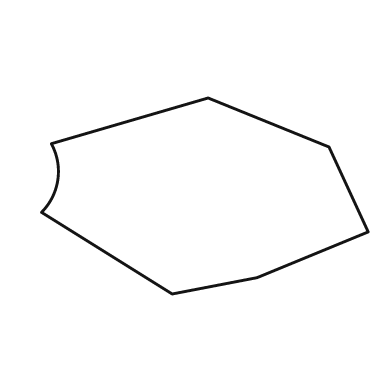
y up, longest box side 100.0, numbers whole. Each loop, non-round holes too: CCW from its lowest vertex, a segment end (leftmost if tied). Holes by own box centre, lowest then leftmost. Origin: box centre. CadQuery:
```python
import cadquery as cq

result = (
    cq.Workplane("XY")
    .moveTo(-10.0, -30.0)
    .lineTo(16.0, -25.0)
    .lineTo(50.0, -11.0)
    .lineTo(38.0, 15.0)
    .lineTo(1.0, 30.0)
    .lineTo(-47.0, 16.0)
    .threePointArc((-45.0, 5.0), (-50.0, -5.0))
    .close()
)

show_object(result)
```